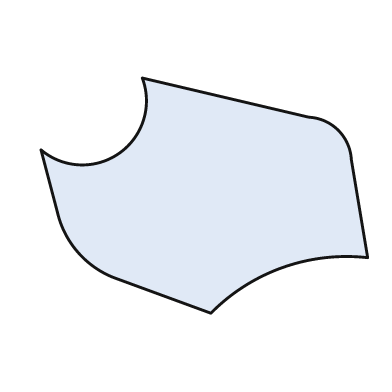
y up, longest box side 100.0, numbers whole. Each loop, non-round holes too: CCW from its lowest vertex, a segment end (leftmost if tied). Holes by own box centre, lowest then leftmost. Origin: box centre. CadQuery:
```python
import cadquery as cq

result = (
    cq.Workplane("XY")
    .moveTo(2.0, -36.0)
    .threePointArc((24.0, -22.0), (50.0, -19.0))
    .lineTo(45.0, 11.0)
    .threePointArc((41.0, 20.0), (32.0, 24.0))
    .lineTo(-19.0, 36.0)
    .threePointArc((-26.0, 13.0), (-50.0, 14.0))
    .lineTo(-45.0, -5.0)
    .threePointArc((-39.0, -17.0), (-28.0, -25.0))
    .close()
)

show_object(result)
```